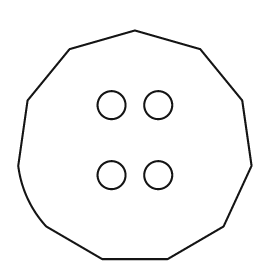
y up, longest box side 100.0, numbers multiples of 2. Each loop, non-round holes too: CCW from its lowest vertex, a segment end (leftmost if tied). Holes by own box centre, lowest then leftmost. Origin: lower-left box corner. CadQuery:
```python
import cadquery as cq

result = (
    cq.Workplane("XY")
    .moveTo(36.0, 0.0)
    .lineTo(64.0, 0.0)
    .lineTo(88.0, 14.0)
    .lineTo(100.0, 40.0)
    .lineTo(96.0, 68.0)
    .lineTo(78.0, 90.0)
    .lineTo(50.0, 98.0)
    .lineTo(22.0, 90.0)
    .lineTo(4.0, 68.0)
    .lineTo(0.0, 40.0)
    .threePointArc((4.0, 26.0), (12.0, 14.0))
    .close()
    .moveTo(40.0, 36.0)
    .circle(6.0)
    .moveTo(60.0, 36.0)
    .circle(6.0)
    .moveTo(40.0, 66.0)
    .circle(6.0)
    .moveTo(60.0, 66.0)
    .circle(6.0)
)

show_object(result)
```